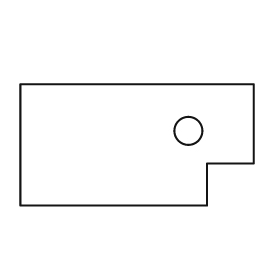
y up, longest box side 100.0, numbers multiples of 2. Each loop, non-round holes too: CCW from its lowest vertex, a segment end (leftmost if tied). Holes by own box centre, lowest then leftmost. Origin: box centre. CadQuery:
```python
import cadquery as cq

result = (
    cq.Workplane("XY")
    .moveTo(-50.0, -26.0)
    .lineTo(30.0, -26.0)
    .lineTo(30.0, -8.0)
    .lineTo(50.0, -8.0)
    .lineTo(50.0, 26.0)
    .lineTo(-50.0, 26.0)
    .close()
    .moveTo(22.0, 6.0)
    .circle(6.0)
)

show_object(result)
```